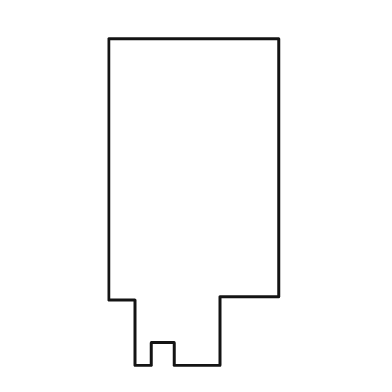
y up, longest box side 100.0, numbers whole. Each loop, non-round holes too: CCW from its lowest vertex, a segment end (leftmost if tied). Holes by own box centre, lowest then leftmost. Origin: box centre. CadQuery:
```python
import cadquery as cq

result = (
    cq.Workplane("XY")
    .moveTo(-18.0, -50.0)
    .lineTo(-13.0, -50.0)
    .lineTo(-13.0, -43.0)
    .lineTo(-6.0, -43.0)
    .lineTo(-6.0, -50.0)
    .lineTo(8.0, -50.0)
    .lineTo(8.0, -29.0)
    .lineTo(26.0, -29.0)
    .lineTo(26.0, 50.0)
    .lineTo(-26.0, 50.0)
    .lineTo(-26.0, -30.0)
    .lineTo(-18.0, -30.0)
    .close()
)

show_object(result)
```